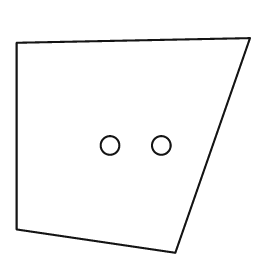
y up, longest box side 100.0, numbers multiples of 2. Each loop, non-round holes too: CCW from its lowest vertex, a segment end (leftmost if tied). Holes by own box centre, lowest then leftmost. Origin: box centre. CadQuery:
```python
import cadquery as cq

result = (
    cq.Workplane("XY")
    .moveTo(18.0, -46.0)
    .lineTo(50.0, 46.0)
    .lineTo(-50.0, 44.0)
    .lineTo(-50.0, -36.0)
    .close()
    .moveTo(-10.0, 0.0)
    .circle(4.0)
    .moveTo(12.0, 0.0)
    .circle(4.0)
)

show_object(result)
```